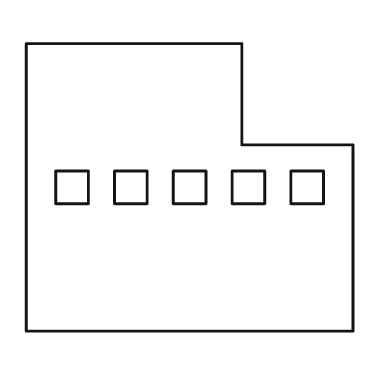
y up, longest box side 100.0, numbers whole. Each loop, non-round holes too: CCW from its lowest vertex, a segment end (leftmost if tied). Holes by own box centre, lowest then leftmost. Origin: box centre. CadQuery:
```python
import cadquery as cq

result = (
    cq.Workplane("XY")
    .moveTo(-50.0, -44.0)
    .lineTo(50.0, -44.0)
    .lineTo(50.0, 13.0)
    .lineTo(16.0, 13.0)
    .lineTo(16.0, 44.0)
    .lineTo(-50.0, 44.0)
    .close()
    .moveTo(-41.0, -5.0)
    .lineTo(-31.0, -5.0)
    .lineTo(-31.0, 5.0)
    .lineTo(-41.0, 5.0)
    .close()
    .moveTo(-23.0, -5.0)
    .lineTo(-13.0, -5.0)
    .lineTo(-13.0, 5.0)
    .lineTo(-23.0, 5.0)
    .close()
    .moveTo(-5.0, -5.0)
    .lineTo(5.0, -5.0)
    .lineTo(5.0, 5.0)
    .lineTo(-5.0, 5.0)
    .close()
    .moveTo(13.0, -5.0)
    .lineTo(23.0, -5.0)
    .lineTo(23.0, 5.0)
    .lineTo(13.0, 5.0)
    .close()
    .moveTo(31.0, -5.0)
    .lineTo(41.0, -5.0)
    .lineTo(41.0, 5.0)
    .lineTo(31.0, 5.0)
    .close()
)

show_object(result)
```